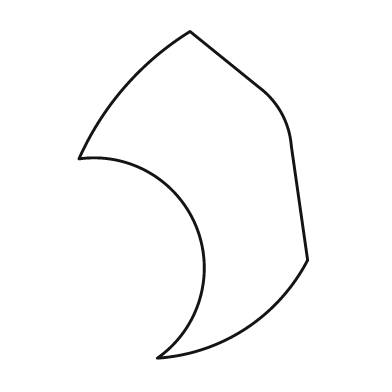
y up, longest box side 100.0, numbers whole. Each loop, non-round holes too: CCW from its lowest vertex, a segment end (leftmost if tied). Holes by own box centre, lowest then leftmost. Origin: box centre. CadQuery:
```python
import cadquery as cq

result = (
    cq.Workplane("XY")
    .moveTo(-11.0, -50.0)
    .threePointArc((16.0, -41.0), (35.0, -20.0))
    .lineTo(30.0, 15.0)
    .threePointArc((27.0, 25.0), (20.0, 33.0))
    .lineTo(-1.0, 50.0)
    .threePointArc((-21.0, 33.0), (-35.0, 11.0))
    .threePointArc((1.0, -10.0), (-11.0, -50.0))
    .close()
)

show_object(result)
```